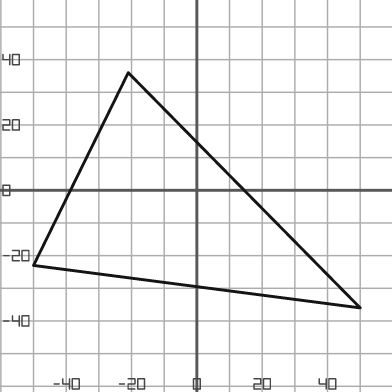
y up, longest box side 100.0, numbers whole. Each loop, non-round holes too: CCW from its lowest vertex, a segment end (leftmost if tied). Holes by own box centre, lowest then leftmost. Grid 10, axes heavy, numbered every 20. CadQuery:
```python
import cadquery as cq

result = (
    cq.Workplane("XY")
    .moveTo(50.0, -36.0)
    .lineTo(-21.0, 36.0)
    .lineTo(-50.0, -23.0)
    .close()
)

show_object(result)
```